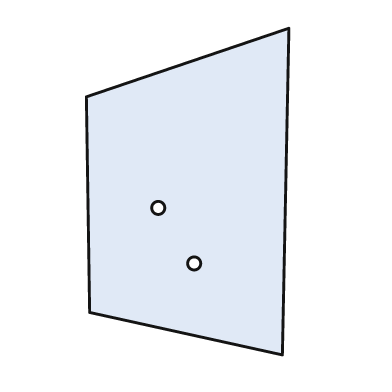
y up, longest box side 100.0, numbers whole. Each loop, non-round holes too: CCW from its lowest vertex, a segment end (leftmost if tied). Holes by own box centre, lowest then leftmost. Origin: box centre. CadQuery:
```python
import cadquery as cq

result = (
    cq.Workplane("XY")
    .moveTo(29.0, -50.0)
    .lineTo(31.0, 50.0)
    .lineTo(-31.0, 29.0)
    .lineTo(-30.0, -37.0)
    .close()
    .moveTo(2.0, -22.0)
    .circle(2.0)
    .moveTo(-9.0, -5.0)
    .circle(2.0)
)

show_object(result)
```